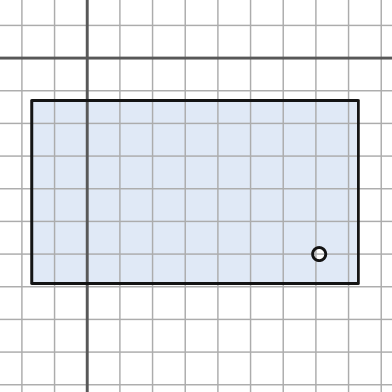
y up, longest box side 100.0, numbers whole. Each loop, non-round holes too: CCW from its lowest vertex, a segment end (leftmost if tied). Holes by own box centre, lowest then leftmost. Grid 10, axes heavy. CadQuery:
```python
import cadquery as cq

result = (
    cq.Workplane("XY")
    .moveTo(-17.0, -69.0)
    .lineTo(83.0, -69.0)
    .lineTo(83.0, -13.0)
    .lineTo(-17.0, -13.0)
    .close()
    .moveTo(71.0, -60.0)
    .circle(2.0)
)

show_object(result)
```